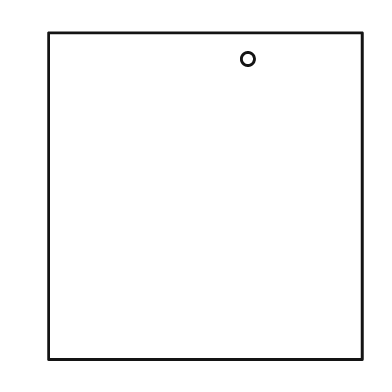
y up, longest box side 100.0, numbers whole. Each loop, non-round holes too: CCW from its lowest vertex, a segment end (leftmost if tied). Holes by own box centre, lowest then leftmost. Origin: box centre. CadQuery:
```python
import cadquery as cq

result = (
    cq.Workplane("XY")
    .moveTo(-48.0, -50.0)
    .lineTo(48.0, -50.0)
    .lineTo(48.0, 50.0)
    .lineTo(-48.0, 50.0)
    .close()
    .moveTo(13.0, 42.0)
    .circle(2.0)
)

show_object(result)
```